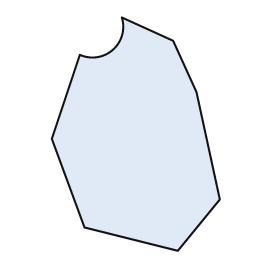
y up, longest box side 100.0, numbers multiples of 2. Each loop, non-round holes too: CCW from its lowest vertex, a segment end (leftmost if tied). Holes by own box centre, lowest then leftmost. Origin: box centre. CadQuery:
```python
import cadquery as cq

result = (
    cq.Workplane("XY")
    .moveTo(18.0, -50.0)
    .lineTo(36.0, -28.0)
    .lineTo(26.0, 18.0)
    .lineTo(16.0, 40.0)
    .lineTo(-6.0, 50.0)
    .threePointArc((-10.0, 36.0), (-24.0, 34.0))
    .lineTo(-36.0, -2.0)
    .lineTo(-22.0, -40.0)
    .close()
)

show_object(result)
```